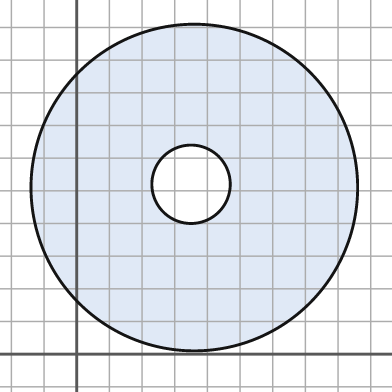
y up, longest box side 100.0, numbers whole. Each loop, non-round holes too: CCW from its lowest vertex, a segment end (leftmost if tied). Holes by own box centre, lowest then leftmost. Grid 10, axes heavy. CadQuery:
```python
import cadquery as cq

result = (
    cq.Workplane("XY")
    .moveTo(36.0, 51.0)
    .circle(50.0)
    .moveTo(35.0, 52.0)
    .circle(12.0)
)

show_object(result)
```